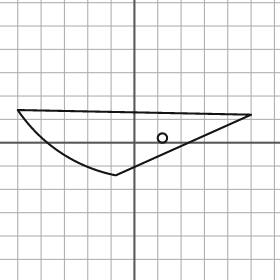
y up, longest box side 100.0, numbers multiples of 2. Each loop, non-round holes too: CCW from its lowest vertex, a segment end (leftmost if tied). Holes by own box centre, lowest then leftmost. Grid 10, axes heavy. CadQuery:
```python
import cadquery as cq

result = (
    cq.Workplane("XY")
    .moveTo(-8.0, -14.0)
    .lineTo(50.0, 12.0)
    .lineTo(-50.0, 14.0)
    .threePointArc((-32.0, -4.0), (-8.0, -14.0))
    .close()
    .moveTo(12.0, 2.0)
    .circle(2.0)
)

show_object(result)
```